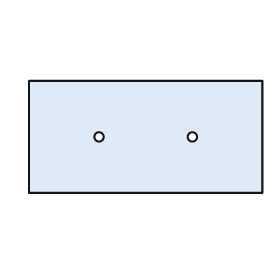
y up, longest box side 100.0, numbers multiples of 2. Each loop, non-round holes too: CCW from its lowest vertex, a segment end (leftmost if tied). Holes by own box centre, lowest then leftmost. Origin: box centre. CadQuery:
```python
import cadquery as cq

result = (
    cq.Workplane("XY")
    .moveTo(-50.0, -24.0)
    .lineTo(50.0, -24.0)
    .lineTo(50.0, 24.0)
    .lineTo(-50.0, 24.0)
    .close()
    .moveTo(-20.0, 0.0)
    .circle(2.0)
    .moveTo(20.0, 0.0)
    .circle(2.0)
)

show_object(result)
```